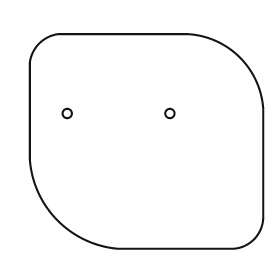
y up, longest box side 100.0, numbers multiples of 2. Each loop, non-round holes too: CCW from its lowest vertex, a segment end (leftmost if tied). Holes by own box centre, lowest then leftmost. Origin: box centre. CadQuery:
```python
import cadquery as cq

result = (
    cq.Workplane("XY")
    .moveTo(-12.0, -46.0)
    .lineTo(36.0, -46.0)
    .threePointArc((46.0, -42.0), (50.0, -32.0))
    .lineTo(50.0, 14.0)
    .threePointArc((40.0, 36.0), (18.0, 46.0))
    .lineTo(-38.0, 46.0)
    .threePointArc((-46.0, 42.0), (-50.0, 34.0))
    .lineTo(-50.0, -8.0)
    .threePointArc((-38.0, -34.0), (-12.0, -46.0))
    .close()
    .moveTo(-34.0, 12.0)
    .circle(2.0)
    .moveTo(10.0, 12.0)
    .circle(2.0)
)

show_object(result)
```